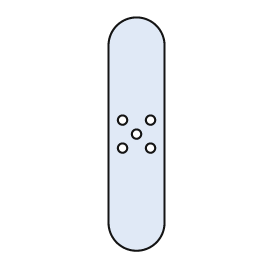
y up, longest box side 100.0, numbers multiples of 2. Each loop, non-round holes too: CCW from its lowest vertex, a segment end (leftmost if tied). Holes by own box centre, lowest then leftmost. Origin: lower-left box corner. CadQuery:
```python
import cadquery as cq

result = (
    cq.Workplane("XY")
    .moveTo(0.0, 12.0)
    .threePointArc((12.0, 0.0), (24.0, 12.0))
    .lineTo(24.0, 88.0)
    .threePointArc((12.0, 100.0), (0.0, 88.0))
    .close()
    .moveTo(6.0, 44.0)
    .circle(2.0)
    .moveTo(18.0, 44.0)
    .circle(2.0)
    .moveTo(12.0, 50.0)
    .circle(2.0)
    .moveTo(6.0, 56.0)
    .circle(2.0)
    .moveTo(18.0, 56.0)
    .circle(2.0)
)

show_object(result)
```